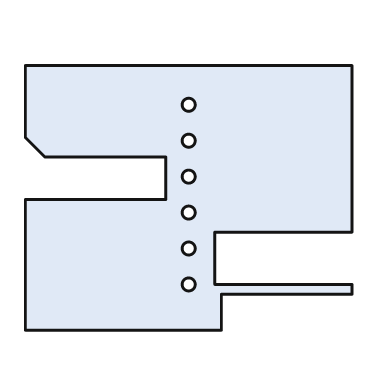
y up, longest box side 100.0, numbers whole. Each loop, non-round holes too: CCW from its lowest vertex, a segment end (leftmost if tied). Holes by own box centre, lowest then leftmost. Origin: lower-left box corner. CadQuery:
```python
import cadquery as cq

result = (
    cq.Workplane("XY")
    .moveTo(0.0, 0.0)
    .lineTo(60.0, 0.0)
    .lineTo(60.0, 11.0)
    .lineTo(100.0, 11.0)
    .lineTo(100.0, 14.0)
    .lineTo(58.0, 14.0)
    .lineTo(58.0, 30.0)
    .lineTo(100.0, 30.0)
    .lineTo(100.0, 81.0)
    .lineTo(0.0, 81.0)
    .lineTo(0.0, 59.0)
    .lineTo(6.0, 53.0)
    .lineTo(43.0, 53.0)
    .lineTo(43.0, 40.0)
    .lineTo(0.0, 40.0)
    .close()
    .moveTo(50.0, 14.0)
    .circle(2.0)
    .moveTo(50.0, 25.0)
    .circle(2.0)
    .moveTo(50.0, 36.0)
    .circle(2.0)
    .moveTo(50.0, 47.0)
    .circle(2.0)
    .moveTo(50.0, 58.0)
    .circle(2.0)
    .moveTo(50.0, 69.0)
    .circle(2.0)
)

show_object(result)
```